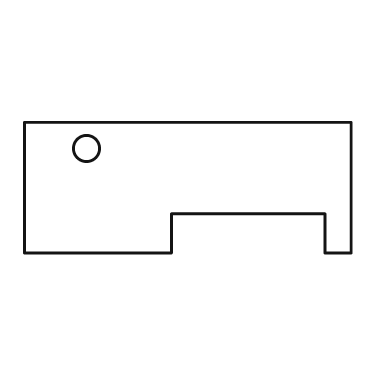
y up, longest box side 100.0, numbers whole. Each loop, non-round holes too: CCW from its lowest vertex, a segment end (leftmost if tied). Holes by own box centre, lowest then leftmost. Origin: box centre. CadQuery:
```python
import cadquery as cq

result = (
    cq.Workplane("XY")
    .moveTo(-50.0, -20.0)
    .lineTo(-5.0, -20.0)
    .lineTo(-5.0, -8.0)
    .lineTo(42.0, -8.0)
    .lineTo(42.0, -20.0)
    .lineTo(50.0, -20.0)
    .lineTo(50.0, 20.0)
    .lineTo(-50.0, 20.0)
    .close()
    .moveTo(-31.0, 12.0)
    .circle(4.0)
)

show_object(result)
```